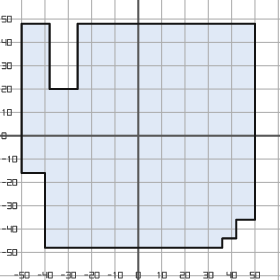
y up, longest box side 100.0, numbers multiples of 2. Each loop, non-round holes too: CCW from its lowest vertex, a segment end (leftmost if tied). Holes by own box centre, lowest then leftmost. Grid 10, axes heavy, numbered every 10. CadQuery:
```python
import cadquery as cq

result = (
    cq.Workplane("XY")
    .moveTo(-40.0, -48.0)
    .lineTo(36.0, -48.0)
    .lineTo(36.0, -44.0)
    .lineTo(42.0, -44.0)
    .lineTo(42.0, -36.0)
    .lineTo(50.0, -36.0)
    .lineTo(50.0, 48.0)
    .lineTo(-26.0, 48.0)
    .lineTo(-26.0, 20.0)
    .lineTo(-38.0, 20.0)
    .lineTo(-38.0, 48.0)
    .lineTo(-50.0, 48.0)
    .lineTo(-50.0, -16.0)
    .lineTo(-40.0, -16.0)
    .close()
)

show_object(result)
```